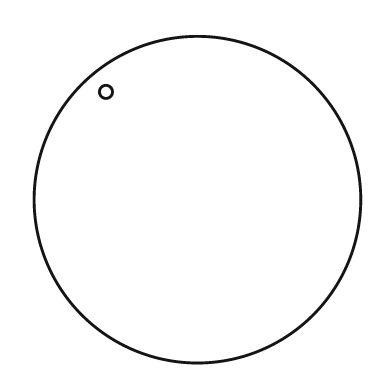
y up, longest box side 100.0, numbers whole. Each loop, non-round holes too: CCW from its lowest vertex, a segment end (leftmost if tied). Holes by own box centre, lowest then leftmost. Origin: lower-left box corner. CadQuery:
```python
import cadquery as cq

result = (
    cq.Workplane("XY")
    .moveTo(50.0, 50.0)
    .circle(50.0)
    .moveTo(22.0, 83.0)
    .circle(2.0)
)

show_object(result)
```